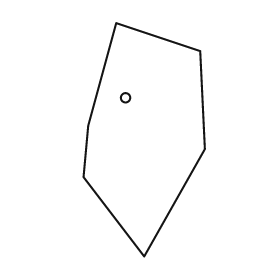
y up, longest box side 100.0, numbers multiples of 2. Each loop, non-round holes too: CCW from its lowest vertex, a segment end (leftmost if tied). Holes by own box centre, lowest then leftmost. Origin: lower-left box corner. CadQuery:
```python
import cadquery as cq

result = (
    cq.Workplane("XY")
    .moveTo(26.0, 0.0)
    .lineTo(52.0, 46.0)
    .lineTo(50.0, 88.0)
    .lineTo(14.0, 100.0)
    .lineTo(2.0, 56.0)
    .lineTo(0.0, 34.0)
    .close()
    .moveTo(18.0, 68.0)
    .circle(2.0)
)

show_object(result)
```